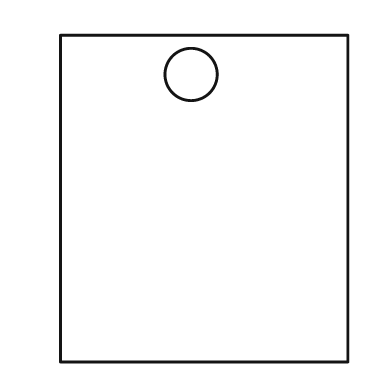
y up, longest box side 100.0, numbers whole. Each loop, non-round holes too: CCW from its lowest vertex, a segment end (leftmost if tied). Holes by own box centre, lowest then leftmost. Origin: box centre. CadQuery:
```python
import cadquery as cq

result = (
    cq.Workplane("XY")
    .moveTo(-44.0, -50.0)
    .lineTo(44.0, -50.0)
    .lineTo(44.0, 50.0)
    .lineTo(-44.0, 50.0)
    .close()
    .moveTo(-4.0, 38.0)
    .circle(8.0)
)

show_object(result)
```